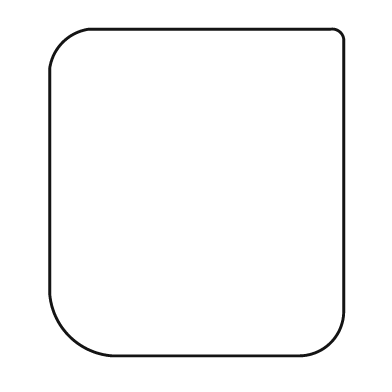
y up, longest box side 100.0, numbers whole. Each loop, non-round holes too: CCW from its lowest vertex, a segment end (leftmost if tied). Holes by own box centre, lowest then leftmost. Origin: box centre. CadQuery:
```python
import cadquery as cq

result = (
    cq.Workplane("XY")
    .moveTo(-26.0, -50.0)
    .lineTo(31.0, -50.0)
    .threePointArc((41.0, -46.0), (45.0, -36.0))
    .lineTo(45.0, 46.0)
    .threePointArc((44.0, 49.0), (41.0, 50.0))
    .lineTo(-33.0, 50.0)
    .threePointArc((-41.0, 46.0), (-45.0, 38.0))
    .lineTo(-45.0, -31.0)
    .threePointArc((-39.0, -44.0), (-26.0, -50.0))
    .close()
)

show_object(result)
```